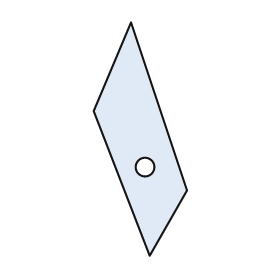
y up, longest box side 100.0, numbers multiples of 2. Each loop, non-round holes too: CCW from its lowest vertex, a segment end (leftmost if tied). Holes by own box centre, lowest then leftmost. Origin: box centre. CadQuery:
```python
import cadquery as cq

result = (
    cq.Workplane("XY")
    .moveTo(4.0, -50.0)
    .lineTo(20.0, -22.0)
    .lineTo(-4.0, 50.0)
    .lineTo(-20.0, 12.0)
    .close()
    .moveTo(2.0, -12.0)
    .circle(4.0)
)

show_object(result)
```